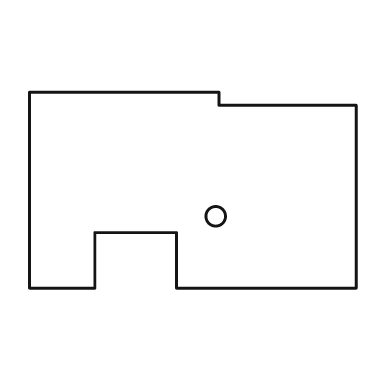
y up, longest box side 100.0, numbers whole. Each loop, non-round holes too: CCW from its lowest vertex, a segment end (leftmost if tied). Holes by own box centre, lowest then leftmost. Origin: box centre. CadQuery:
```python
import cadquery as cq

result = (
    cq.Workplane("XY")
    .moveTo(-50.0, -30.0)
    .lineTo(-30.0, -30.0)
    .lineTo(-30.0, -13.0)
    .lineTo(-5.0, -13.0)
    .lineTo(-5.0, -30.0)
    .lineTo(50.0, -30.0)
    .lineTo(50.0, 26.0)
    .lineTo(8.0, 26.0)
    .lineTo(8.0, 30.0)
    .lineTo(-50.0, 30.0)
    .close()
    .moveTo(7.0, -8.0)
    .circle(3.0)
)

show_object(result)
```